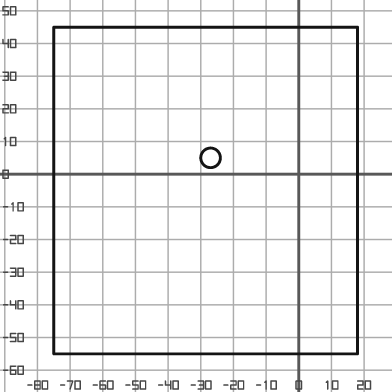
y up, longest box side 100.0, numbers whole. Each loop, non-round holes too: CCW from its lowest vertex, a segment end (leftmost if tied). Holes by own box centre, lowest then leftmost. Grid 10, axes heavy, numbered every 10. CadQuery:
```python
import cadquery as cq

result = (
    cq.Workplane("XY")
    .moveTo(-75.0, -55.0)
    .lineTo(18.0, -55.0)
    .lineTo(18.0, 45.0)
    .lineTo(-75.0, 45.0)
    .close()
    .moveTo(-27.0, 5.0)
    .circle(3.0)
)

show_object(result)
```